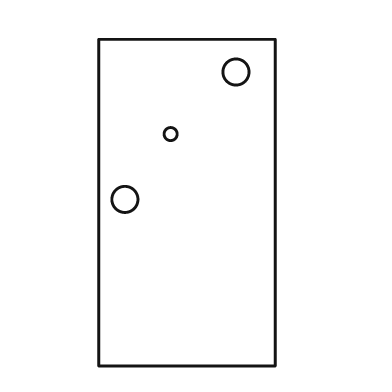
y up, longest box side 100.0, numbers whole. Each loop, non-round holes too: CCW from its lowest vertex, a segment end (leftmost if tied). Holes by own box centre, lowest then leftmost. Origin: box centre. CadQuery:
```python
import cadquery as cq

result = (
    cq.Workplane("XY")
    .moveTo(-27.0, -50.0)
    .lineTo(27.0, -50.0)
    .lineTo(27.0, 50.0)
    .lineTo(-27.0, 50.0)
    .close()
    .moveTo(-19.0, 1.0)
    .circle(4.0)
    .moveTo(-5.0, 21.0)
    .circle(2.0)
    .moveTo(15.0, 40.0)
    .circle(4.0)
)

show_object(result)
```